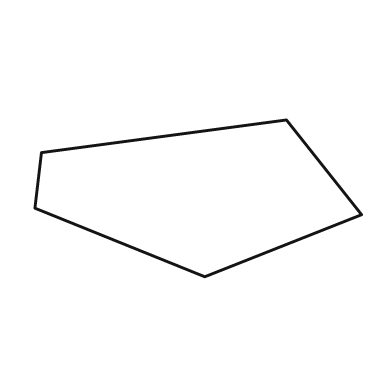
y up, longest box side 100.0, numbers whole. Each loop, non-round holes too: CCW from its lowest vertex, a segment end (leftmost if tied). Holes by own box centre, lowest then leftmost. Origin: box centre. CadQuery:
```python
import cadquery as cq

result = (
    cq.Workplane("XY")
    .moveTo(2.0, -24.0)
    .lineTo(50.0, -5.0)
    .lineTo(27.0, 24.0)
    .lineTo(-48.0, 14.0)
    .lineTo(-50.0, -3.0)
    .close()
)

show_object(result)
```